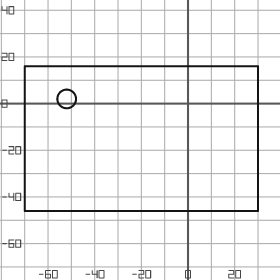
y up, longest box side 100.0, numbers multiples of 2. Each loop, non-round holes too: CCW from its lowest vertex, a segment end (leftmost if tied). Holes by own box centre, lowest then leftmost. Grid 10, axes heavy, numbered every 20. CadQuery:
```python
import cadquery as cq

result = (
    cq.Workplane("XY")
    .moveTo(-70.0, -46.0)
    .lineTo(30.0, -46.0)
    .lineTo(30.0, 16.0)
    .lineTo(-70.0, 16.0)
    .close()
    .moveTo(-52.0, 2.0)
    .circle(4.0)
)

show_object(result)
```